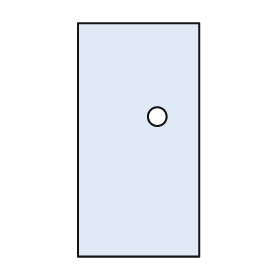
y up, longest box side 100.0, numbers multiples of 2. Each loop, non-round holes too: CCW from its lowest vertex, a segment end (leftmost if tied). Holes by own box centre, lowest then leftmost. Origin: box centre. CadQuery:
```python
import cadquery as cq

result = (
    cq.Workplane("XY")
    .moveTo(-26.0, -50.0)
    .lineTo(26.0, -50.0)
    .lineTo(26.0, 50.0)
    .lineTo(-26.0, 50.0)
    .close()
    .moveTo(8.0, 10.0)
    .circle(4.0)
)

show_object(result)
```